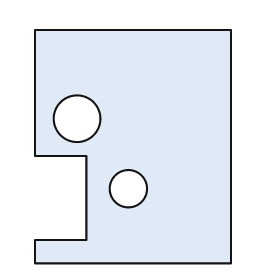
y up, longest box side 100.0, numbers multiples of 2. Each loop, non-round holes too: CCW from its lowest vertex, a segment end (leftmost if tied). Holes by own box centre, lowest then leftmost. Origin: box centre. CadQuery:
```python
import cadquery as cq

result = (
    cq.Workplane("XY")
    .moveTo(-42.0, -50.0)
    .lineTo(42.0, -50.0)
    .lineTo(42.0, 50.0)
    .lineTo(-42.0, 50.0)
    .lineTo(-42.0, -4.0)
    .lineTo(-20.0, -4.0)
    .lineTo(-20.0, -40.0)
    .lineTo(-42.0, -40.0)
    .close()
    .moveTo(-2.0, -18.0)
    .circle(8.0)
    .moveTo(-24.0, 12.0)
    .circle(10.0)
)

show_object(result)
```